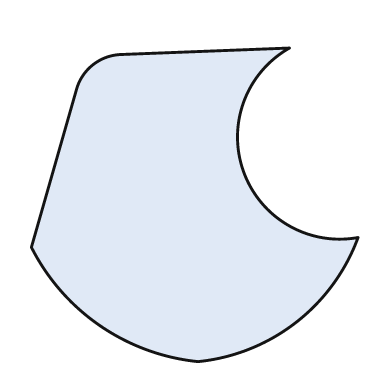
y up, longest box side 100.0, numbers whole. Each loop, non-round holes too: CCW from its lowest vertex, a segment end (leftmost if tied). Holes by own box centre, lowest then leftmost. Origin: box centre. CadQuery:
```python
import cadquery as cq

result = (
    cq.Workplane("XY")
    .moveTo(1.0, -48.0)
    .threePointArc((31.0, -36.0), (50.0, -10.0))
    .threePointArc((15.0, 10.0), (29.0, 48.0))
    .lineTo(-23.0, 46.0)
    .threePointArc((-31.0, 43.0), (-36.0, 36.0))
    .lineTo(-50.0, -13.0)
    .threePointArc((-29.0, -37.0), (1.0, -48.0))
    .close()
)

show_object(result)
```